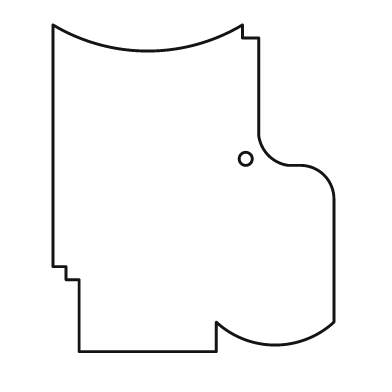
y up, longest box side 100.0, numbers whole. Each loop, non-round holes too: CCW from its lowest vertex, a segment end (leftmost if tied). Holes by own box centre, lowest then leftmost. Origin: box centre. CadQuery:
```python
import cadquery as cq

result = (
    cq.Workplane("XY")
    .moveTo(-35.0, -50.0)
    .lineTo(7.0, -50.0)
    .lineTo(7.0, -41.0)
    .threePointArc((25.0, -48.0), (43.0, -41.0))
    .lineTo(43.0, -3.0)
    .threePointArc((40.0, 4.0), (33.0, 7.0))
    .lineTo(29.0, 7.0)
    .threePointArc((23.0, 10.0), (20.0, 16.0))
    .lineTo(20.0, 46.0)
    .lineTo(15.0, 46.0)
    .lineTo(15.0, 50.0)
    .threePointArc((-14.0, 42.0), (-43.0, 50.0))
    .lineTo(-43.0, -24.0)
    .lineTo(-39.0, -24.0)
    .lineTo(-39.0, -28.0)
    .lineTo(-35.0, -28.0)
    .close()
    .moveTo(16.0, 9.0)
    .circle(2.0)
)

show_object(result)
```